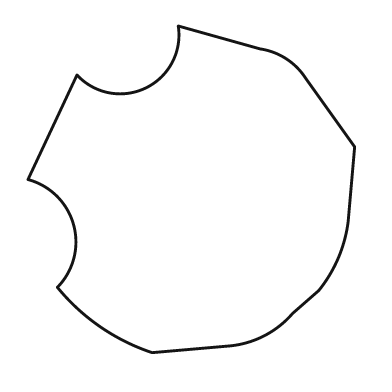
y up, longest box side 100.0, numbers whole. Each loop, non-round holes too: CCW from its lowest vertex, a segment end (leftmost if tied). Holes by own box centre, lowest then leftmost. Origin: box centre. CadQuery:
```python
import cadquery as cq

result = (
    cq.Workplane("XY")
    .moveTo(-12.0, -50.0)
    .lineTo(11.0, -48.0)
    .threePointArc((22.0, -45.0), (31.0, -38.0))
    .lineTo(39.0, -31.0)
    .threePointArc((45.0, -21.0), (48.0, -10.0))
    .lineTo(50.0, 13.0)
    .lineTo(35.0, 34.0)
    .threePointArc((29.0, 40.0), (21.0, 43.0))
    .lineTo(-4.0, 50.0)
    .threePointArc((-14.0, 31.0), (-35.0, 35.0))
    .lineTo(-50.0, 3.0)
    .threePointArc((-36.0, -11.0), (-41.0, -30.0))
    .threePointArc((-28.0, -42.0), (-12.0, -50.0))
    .close()
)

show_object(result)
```